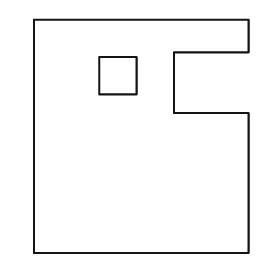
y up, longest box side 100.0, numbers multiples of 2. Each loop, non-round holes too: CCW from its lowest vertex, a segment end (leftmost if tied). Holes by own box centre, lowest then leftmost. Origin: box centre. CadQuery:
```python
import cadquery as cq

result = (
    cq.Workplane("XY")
    .moveTo(-46.0, -50.0)
    .lineTo(46.0, -50.0)
    .lineTo(46.0, 10.0)
    .lineTo(14.0, 10.0)
    .lineTo(14.0, 36.0)
    .lineTo(46.0, 36.0)
    .lineTo(46.0, 50.0)
    .lineTo(-46.0, 50.0)
    .close()
    .moveTo(-18.0, 18.0)
    .lineTo(-2.0, 18.0)
    .lineTo(-2.0, 34.0)
    .lineTo(-18.0, 34.0)
    .close()
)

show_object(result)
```